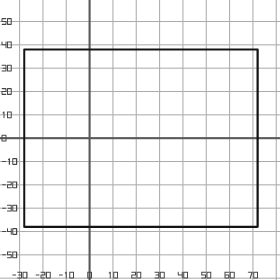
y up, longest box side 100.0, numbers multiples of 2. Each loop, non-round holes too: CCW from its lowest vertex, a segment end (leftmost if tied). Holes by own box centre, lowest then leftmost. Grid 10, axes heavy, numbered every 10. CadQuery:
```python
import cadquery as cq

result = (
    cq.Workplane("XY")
    .moveTo(-28.0, -38.0)
    .lineTo(72.0, -38.0)
    .lineTo(72.0, 38.0)
    .lineTo(-28.0, 38.0)
    .close()
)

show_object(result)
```